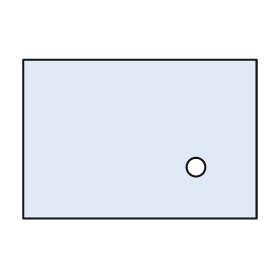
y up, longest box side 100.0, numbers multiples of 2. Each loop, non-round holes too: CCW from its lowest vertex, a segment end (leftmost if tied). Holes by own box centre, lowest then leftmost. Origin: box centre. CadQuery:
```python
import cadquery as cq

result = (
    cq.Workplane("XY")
    .moveTo(-50.0, -34.0)
    .lineTo(50.0, -34.0)
    .lineTo(50.0, 34.0)
    .lineTo(-50.0, 34.0)
    .close()
    .moveTo(24.0, -12.0)
    .circle(4.0)
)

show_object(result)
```